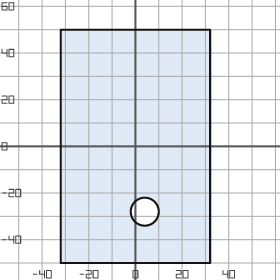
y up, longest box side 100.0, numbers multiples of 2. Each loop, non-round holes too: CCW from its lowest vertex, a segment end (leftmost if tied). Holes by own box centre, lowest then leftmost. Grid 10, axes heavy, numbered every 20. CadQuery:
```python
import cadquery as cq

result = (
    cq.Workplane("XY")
    .moveTo(-32.0, -50.0)
    .lineTo(32.0, -50.0)
    .lineTo(32.0, 50.0)
    .lineTo(-32.0, 50.0)
    .close()
    .moveTo(4.0, -28.0)
    .circle(6.0)
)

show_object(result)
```